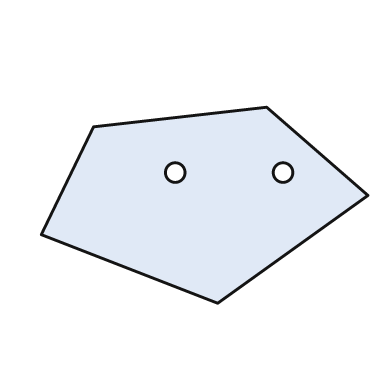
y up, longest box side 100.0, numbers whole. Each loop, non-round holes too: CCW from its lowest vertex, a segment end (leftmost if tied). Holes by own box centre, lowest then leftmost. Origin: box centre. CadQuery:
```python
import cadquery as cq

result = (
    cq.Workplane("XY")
    .moveTo(4.0, -30.0)
    .lineTo(50.0, 3.0)
    .lineTo(19.0, 30.0)
    .lineTo(-34.0, 24.0)
    .lineTo(-50.0, -9.0)
    .close()
    .moveTo(-9.0, 10.0)
    .circle(3.0)
    .moveTo(24.0, 10.0)
    .circle(3.0)
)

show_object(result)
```